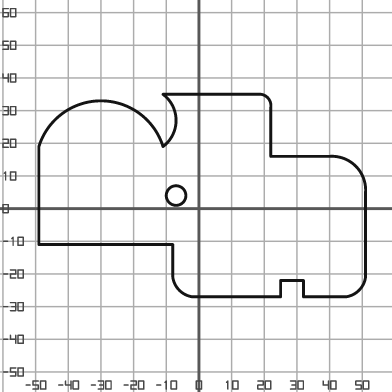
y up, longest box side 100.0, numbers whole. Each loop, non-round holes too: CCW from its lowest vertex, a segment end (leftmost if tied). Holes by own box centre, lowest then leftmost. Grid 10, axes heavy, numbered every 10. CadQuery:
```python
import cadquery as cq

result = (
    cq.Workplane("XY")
    .moveTo(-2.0, -27.0)
    .lineTo(25.0, -27.0)
    .lineTo(25.0, -22.0)
    .lineTo(32.0, -22.0)
    .lineTo(32.0, -27.0)
    .lineTo(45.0, -27.0)
    .threePointArc((49.0, -25.0), (51.0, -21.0))
    .lineTo(51.0, 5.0)
    .threePointArc((48.0, 13.0), (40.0, 16.0))
    .lineTo(22.0, 16.0)
    .lineTo(22.0, 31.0)
    .threePointArc((21.0, 34.0), (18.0, 35.0))
    .lineTo(-11.0, 35.0)
    .threePointArc((-7.0, 27.0), (-11.0, 19.0))
    .threePointArc((-30.0, 33.0), (-49.0, 19.0))
    .lineTo(-49.0, -11.0)
    .lineTo(-8.0, -11.0)
    .lineTo(-8.0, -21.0)
    .threePointArc((-6.0, -25.0), (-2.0, -27.0))
    .close()
    .moveTo(-7.0, 4.0)
    .circle(3.0)
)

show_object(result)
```